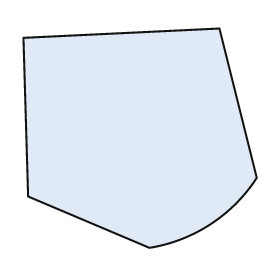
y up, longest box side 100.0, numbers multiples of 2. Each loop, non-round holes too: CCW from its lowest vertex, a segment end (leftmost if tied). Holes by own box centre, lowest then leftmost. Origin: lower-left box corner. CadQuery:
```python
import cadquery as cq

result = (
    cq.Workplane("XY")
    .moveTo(54.0, 0.0)
    .threePointArc((80.0, 10.0), (100.0, 30.0))
    .lineTo(84.0, 94.0)
    .lineTo(0.0, 90.0)
    .lineTo(2.0, 22.0)
    .close()
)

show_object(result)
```